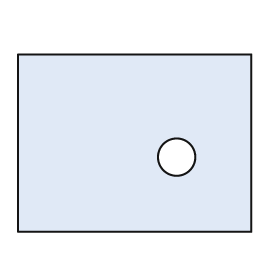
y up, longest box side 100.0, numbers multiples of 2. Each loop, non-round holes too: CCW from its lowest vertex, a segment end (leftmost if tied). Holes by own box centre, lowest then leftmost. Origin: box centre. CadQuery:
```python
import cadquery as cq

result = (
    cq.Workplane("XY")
    .moveTo(-50.0, -38.0)
    .lineTo(50.0, -38.0)
    .lineTo(50.0, 38.0)
    .lineTo(-50.0, 38.0)
    .close()
    .moveTo(18.0, -6.0)
    .circle(8.0)
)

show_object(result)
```